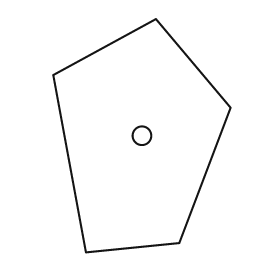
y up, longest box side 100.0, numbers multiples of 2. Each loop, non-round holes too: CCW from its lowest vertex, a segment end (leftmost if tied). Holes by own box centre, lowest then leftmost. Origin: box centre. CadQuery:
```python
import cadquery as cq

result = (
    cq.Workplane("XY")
    .moveTo(-24.0, -50.0)
    .lineTo(16.0, -46.0)
    .lineTo(38.0, 12.0)
    .lineTo(6.0, 50.0)
    .lineTo(-38.0, 26.0)
    .close()
    .moveTo(0.0, 0.0)
    .circle(4.0)
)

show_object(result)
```